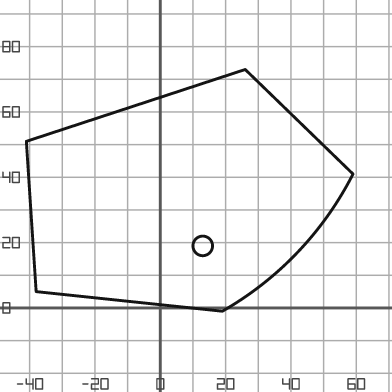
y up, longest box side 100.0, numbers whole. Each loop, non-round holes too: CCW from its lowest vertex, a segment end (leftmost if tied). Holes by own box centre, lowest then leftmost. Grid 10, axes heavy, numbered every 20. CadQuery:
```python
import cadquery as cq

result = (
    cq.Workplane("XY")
    .moveTo(19.0, -1.0)
    .threePointArc((42.0, 17.0), (59.0, 41.0))
    .lineTo(26.0, 73.0)
    .lineTo(-41.0, 51.0)
    .lineTo(-38.0, 5.0)
    .close()
    .moveTo(13.0, 19.0)
    .circle(3.0)
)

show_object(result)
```